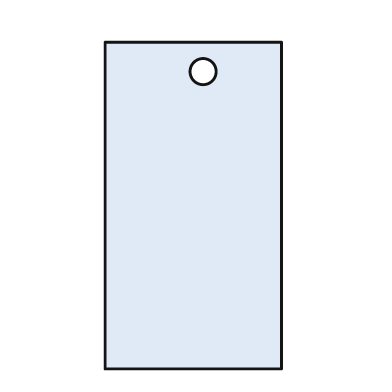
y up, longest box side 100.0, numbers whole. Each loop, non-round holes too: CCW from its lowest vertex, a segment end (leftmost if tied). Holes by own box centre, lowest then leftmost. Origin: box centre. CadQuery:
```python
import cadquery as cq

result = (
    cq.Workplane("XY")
    .moveTo(-27.0, -50.0)
    .lineTo(27.0, -50.0)
    .lineTo(27.0, 50.0)
    .lineTo(-27.0, 50.0)
    .close()
    .moveTo(3.0, 41.0)
    .circle(4.0)
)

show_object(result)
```